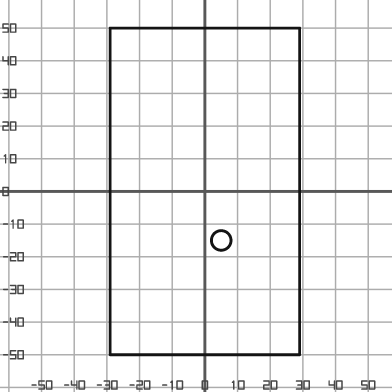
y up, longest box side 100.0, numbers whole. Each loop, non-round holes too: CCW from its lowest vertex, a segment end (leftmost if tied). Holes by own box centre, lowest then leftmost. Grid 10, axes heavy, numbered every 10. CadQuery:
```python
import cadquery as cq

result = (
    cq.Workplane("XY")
    .moveTo(-29.0, -50.0)
    .lineTo(29.0, -50.0)
    .lineTo(29.0, 50.0)
    .lineTo(-29.0, 50.0)
    .close()
    .moveTo(5.0, -15.0)
    .circle(3.0)
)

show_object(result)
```